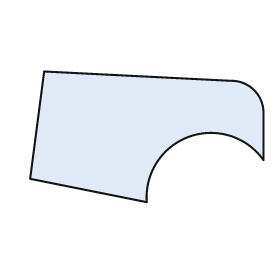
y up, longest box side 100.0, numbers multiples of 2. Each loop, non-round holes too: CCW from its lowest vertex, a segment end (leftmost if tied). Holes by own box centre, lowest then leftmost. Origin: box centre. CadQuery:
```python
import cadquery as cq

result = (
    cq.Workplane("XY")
    .moveTo(0.0, -28.0)
    .threePointArc((18.0, 0.0), (50.0, -10.0))
    .lineTo(50.0, 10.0)
    .threePointArc((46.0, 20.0), (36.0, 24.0))
    .lineTo(-44.0, 28.0)
    .lineTo(-50.0, -18.0)
    .close()
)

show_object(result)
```